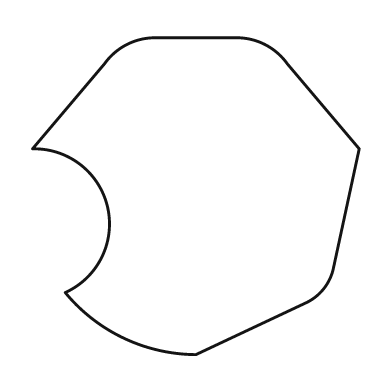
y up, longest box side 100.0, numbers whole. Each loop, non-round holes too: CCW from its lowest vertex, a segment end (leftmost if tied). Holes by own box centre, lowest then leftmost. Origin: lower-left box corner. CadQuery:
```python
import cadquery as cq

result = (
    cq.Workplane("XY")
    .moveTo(50.0, 0.0)
    .lineTo(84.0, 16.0)
    .threePointArc((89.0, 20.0), (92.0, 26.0))
    .lineTo(100.0, 63.0)
    .lineTo(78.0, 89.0)
    .threePointArc((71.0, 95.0), (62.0, 97.0))
    .lineTo(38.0, 97.0)
    .threePointArc((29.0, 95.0), (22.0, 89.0))
    .lineTo(0.0, 63.0)
    .threePointArc((23.0, 45.0), (10.0, 19.0))
    .threePointArc((28.0, 5.0), (50.0, 0.0))
    .close()
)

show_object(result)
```